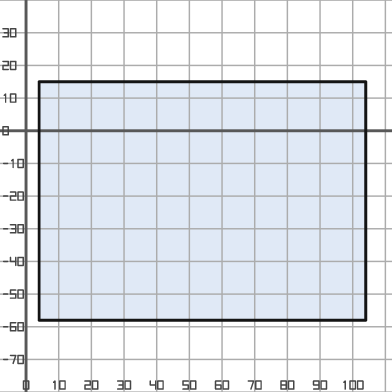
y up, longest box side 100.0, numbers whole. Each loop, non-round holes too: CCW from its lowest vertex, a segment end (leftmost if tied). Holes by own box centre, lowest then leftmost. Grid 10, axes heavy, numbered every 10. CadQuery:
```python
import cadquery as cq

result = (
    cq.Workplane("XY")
    .moveTo(4.0, -58.0)
    .lineTo(104.0, -58.0)
    .lineTo(104.0, 15.0)
    .lineTo(4.0, 15.0)
    .close()
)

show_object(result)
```